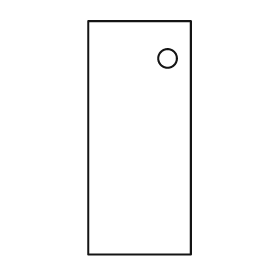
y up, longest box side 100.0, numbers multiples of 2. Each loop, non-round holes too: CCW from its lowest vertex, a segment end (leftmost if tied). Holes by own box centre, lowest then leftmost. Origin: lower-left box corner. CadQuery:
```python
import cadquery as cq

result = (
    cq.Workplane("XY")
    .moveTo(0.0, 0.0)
    .lineTo(44.0, 0.0)
    .lineTo(44.0, 100.0)
    .lineTo(0.0, 100.0)
    .close()
    .moveTo(34.0, 84.0)
    .circle(4.0)
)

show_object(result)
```